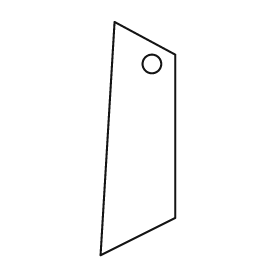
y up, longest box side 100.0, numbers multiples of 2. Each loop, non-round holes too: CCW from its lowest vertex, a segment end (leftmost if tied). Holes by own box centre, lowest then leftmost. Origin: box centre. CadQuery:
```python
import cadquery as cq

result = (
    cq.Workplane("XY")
    .moveTo(-16.0, -50.0)
    .lineTo(16.0, -34.0)
    .lineTo(16.0, 36.0)
    .lineTo(-10.0, 50.0)
    .close()
    .moveTo(6.0, 32.0)
    .circle(4.0)
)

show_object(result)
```